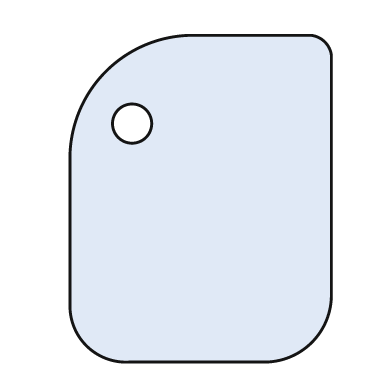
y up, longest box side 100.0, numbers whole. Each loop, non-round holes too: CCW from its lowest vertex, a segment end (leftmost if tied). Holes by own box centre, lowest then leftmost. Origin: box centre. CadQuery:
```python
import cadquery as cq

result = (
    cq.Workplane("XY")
    .moveTo(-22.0, -50.0)
    .lineTo(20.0, -50.0)
    .threePointArc((34.0, -44.0), (40.0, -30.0))
    .lineTo(40.0, 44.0)
    .threePointArc((38.0, 48.0), (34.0, 50.0))
    .lineTo(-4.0, 50.0)
    .threePointArc((-29.0, 39.0), (-40.0, 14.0))
    .lineTo(-40.0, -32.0)
    .threePointArc((-35.0, -45.0), (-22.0, -50.0))
    .close()
    .moveTo(-21.0, 23.0)
    .circle(6.0)
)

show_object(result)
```